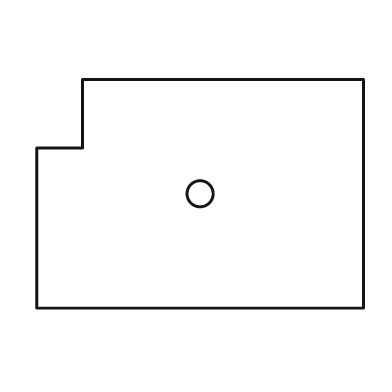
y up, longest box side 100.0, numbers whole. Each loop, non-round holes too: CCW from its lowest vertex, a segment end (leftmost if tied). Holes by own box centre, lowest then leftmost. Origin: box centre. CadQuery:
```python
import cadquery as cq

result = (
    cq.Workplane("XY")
    .moveTo(-50.0, -35.0)
    .lineTo(50.0, -35.0)
    .lineTo(50.0, 35.0)
    .lineTo(-36.0, 35.0)
    .lineTo(-36.0, 14.0)
    .lineTo(-50.0, 14.0)
    .close()
    .moveTo(0.0, 0.0)
    .circle(4.0)
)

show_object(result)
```